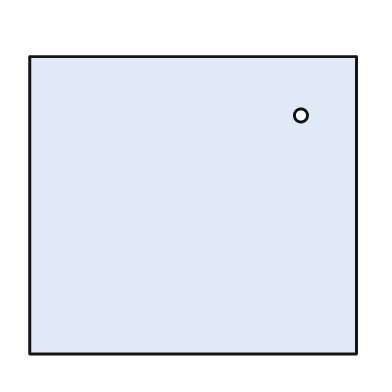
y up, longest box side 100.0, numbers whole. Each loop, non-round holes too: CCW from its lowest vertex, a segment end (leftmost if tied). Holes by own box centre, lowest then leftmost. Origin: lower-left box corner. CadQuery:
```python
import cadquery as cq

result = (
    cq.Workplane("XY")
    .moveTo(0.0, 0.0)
    .lineTo(100.0, 0.0)
    .lineTo(100.0, 91.0)
    .lineTo(0.0, 91.0)
    .close()
    .moveTo(83.0, 73.0)
    .circle(2.0)
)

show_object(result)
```